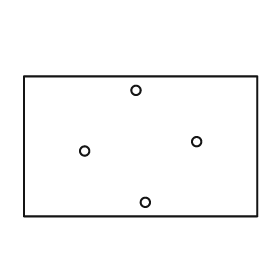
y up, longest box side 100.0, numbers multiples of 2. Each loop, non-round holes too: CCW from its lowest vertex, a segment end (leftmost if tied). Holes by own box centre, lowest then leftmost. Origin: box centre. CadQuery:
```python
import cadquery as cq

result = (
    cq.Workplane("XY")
    .moveTo(-50.0, -30.0)
    .lineTo(50.0, -30.0)
    .lineTo(50.0, 30.0)
    .lineTo(-50.0, 30.0)
    .close()
    .moveTo(2.0, -24.0)
    .circle(2.0)
    .moveTo(-24.0, -2.0)
    .circle(2.0)
    .moveTo(24.0, 2.0)
    .circle(2.0)
    .moveTo(-2.0, 24.0)
    .circle(2.0)
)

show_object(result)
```